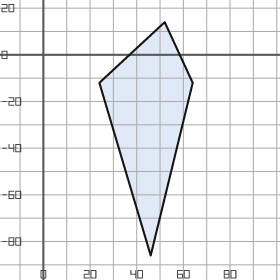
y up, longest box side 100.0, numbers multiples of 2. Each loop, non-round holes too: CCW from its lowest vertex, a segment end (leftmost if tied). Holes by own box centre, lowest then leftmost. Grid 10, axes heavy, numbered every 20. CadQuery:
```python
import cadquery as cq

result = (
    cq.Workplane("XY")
    .moveTo(46.0, -86.0)
    .lineTo(64.0, -12.0)
    .lineTo(52.0, 14.0)
    .lineTo(24.0, -12.0)
    .close()
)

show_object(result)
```